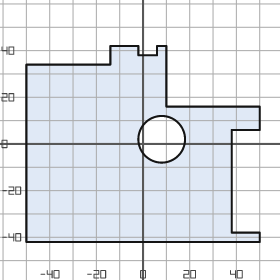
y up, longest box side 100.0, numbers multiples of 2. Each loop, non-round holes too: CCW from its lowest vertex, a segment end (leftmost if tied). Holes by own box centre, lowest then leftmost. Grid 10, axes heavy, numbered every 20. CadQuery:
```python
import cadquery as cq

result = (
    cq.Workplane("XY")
    .moveTo(-50.0, -42.0)
    .lineTo(50.0, -42.0)
    .lineTo(50.0, -38.0)
    .lineTo(38.0, -38.0)
    .lineTo(38.0, 6.0)
    .lineTo(50.0, 6.0)
    .lineTo(50.0, 16.0)
    .lineTo(10.0, 16.0)
    .lineTo(10.0, 42.0)
    .lineTo(6.0, 42.0)
    .lineTo(6.0, 38.0)
    .lineTo(-2.0, 38.0)
    .lineTo(-2.0, 42.0)
    .lineTo(-14.0, 42.0)
    .lineTo(-14.0, 34.0)
    .lineTo(-50.0, 34.0)
    .close()
    .moveTo(8.0, 2.0)
    .circle(10.0)
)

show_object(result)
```